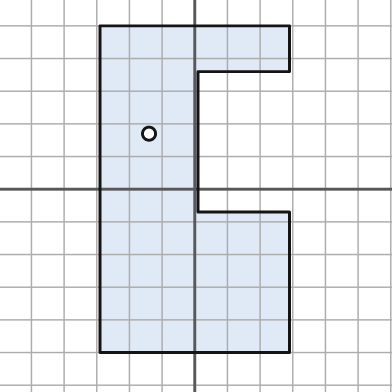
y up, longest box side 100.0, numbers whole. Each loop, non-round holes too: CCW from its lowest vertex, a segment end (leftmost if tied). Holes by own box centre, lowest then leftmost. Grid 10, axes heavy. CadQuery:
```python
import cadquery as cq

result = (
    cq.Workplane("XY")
    .moveTo(-29.0, -50.0)
    .lineTo(29.0, -50.0)
    .lineTo(29.0, -7.0)
    .lineTo(1.0, -7.0)
    .lineTo(1.0, 36.0)
    .lineTo(29.0, 36.0)
    .lineTo(29.0, 50.0)
    .lineTo(-29.0, 50.0)
    .close()
    .moveTo(-14.0, 17.0)
    .circle(2.0)
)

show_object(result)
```